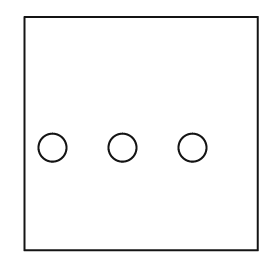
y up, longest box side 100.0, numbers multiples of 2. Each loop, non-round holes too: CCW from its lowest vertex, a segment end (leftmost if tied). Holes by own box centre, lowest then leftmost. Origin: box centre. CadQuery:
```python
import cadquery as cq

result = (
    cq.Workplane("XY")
    .moveTo(-50.0, -50.0)
    .lineTo(50.0, -50.0)
    .lineTo(50.0, 50.0)
    .lineTo(-50.0, 50.0)
    .close()
    .moveTo(-38.0, -6.0)
    .circle(6.0)
    .moveTo(-8.0, -6.0)
    .circle(6.0)
    .moveTo(22.0, -6.0)
    .circle(6.0)
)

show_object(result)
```